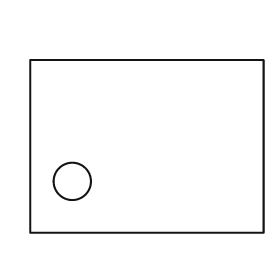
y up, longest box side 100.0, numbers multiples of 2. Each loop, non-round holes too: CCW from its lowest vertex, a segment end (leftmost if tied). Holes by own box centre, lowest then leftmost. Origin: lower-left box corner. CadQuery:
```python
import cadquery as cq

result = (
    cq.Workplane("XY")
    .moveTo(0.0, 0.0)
    .lineTo(100.0, 0.0)
    .lineTo(100.0, 74.0)
    .lineTo(0.0, 74.0)
    .close()
    .moveTo(18.0, 22.0)
    .circle(8.0)
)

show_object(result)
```